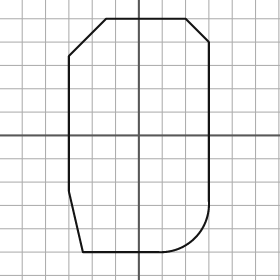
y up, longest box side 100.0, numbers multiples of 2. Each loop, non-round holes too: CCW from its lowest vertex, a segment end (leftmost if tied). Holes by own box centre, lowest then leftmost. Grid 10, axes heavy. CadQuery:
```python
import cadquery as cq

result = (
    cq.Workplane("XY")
    .moveTo(-24.0, -50.0)
    .lineTo(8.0, -50.0)
    .threePointArc((24.0, -44.0), (30.0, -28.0))
    .lineTo(30.0, 40.0)
    .lineTo(20.0, 50.0)
    .lineTo(-14.0, 50.0)
    .lineTo(-30.0, 34.0)
    .lineTo(-30.0, -24.0)
    .close()
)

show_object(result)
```